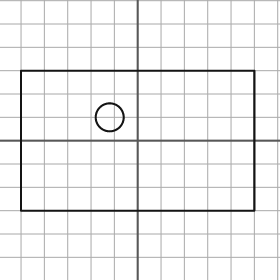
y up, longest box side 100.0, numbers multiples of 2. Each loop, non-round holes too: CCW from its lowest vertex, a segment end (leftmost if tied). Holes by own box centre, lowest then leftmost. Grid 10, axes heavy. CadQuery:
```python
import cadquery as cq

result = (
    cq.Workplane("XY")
    .moveTo(-50.0, -30.0)
    .lineTo(50.0, -30.0)
    .lineTo(50.0, 30.0)
    .lineTo(-50.0, 30.0)
    .close()
    .moveTo(-12.0, 10.0)
    .circle(6.0)
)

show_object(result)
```